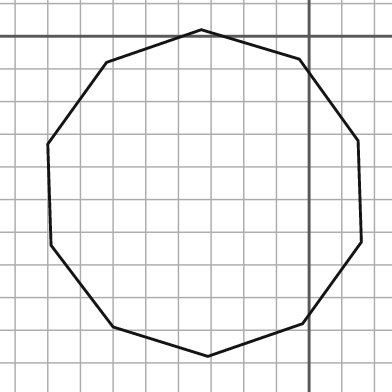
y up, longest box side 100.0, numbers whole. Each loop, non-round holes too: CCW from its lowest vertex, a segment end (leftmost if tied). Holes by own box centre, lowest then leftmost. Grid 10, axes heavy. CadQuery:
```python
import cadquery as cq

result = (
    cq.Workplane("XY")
    .moveTo(-31.0, -98.0)
    .lineTo(-2.0, -88.0)
    .lineTo(16.0, -63.0)
    .lineTo(15.0, -32.0)
    .lineTo(-3.0, -7.0)
    .lineTo(-33.0, 2.0)
    .lineTo(-62.0, -8.0)
    .lineTo(-80.0, -33.0)
    .lineTo(-79.0, -64.0)
    .lineTo(-60.0, -89.0)
    .close()
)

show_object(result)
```